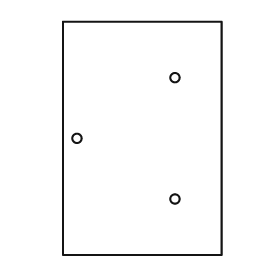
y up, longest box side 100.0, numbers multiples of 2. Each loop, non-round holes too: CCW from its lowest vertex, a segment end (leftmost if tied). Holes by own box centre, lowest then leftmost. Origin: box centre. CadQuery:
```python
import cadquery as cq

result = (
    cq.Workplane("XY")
    .moveTo(-34.0, -50.0)
    .lineTo(34.0, -50.0)
    .lineTo(34.0, 50.0)
    .lineTo(-34.0, 50.0)
    .close()
    .moveTo(14.0, -26.0)
    .circle(2.0)
    .moveTo(-28.0, 0.0)
    .circle(2.0)
    .moveTo(14.0, 26.0)
    .circle(2.0)
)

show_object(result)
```